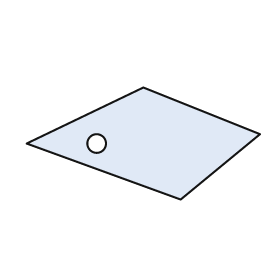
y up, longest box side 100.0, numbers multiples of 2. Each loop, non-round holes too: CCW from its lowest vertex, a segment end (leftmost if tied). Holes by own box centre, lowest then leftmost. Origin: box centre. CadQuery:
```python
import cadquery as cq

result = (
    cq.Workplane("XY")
    .moveTo(16.0, -24.0)
    .lineTo(50.0, 4.0)
    .lineTo(0.0, 24.0)
    .lineTo(-50.0, 0.0)
    .close()
    .moveTo(-20.0, 0.0)
    .circle(4.0)
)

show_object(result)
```